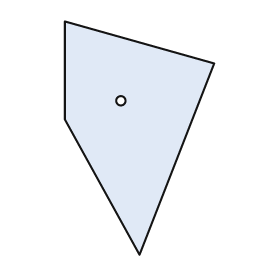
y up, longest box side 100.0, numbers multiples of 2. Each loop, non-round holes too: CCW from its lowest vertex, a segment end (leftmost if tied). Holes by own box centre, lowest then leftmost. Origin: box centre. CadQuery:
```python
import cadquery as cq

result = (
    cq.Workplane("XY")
    .moveTo(0.0, -50.0)
    .lineTo(32.0, 32.0)
    .lineTo(-32.0, 50.0)
    .lineTo(-32.0, 8.0)
    .close()
    .moveTo(-8.0, 16.0)
    .circle(2.0)
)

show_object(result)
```